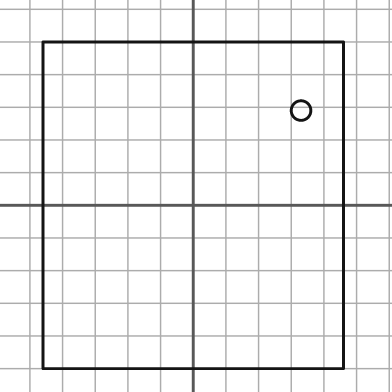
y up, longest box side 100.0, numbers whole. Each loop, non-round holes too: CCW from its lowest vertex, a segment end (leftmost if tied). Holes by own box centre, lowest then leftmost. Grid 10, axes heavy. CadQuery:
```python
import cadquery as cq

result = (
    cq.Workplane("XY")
    .moveTo(-46.0, -50.0)
    .lineTo(46.0, -50.0)
    .lineTo(46.0, 50.0)
    .lineTo(-46.0, 50.0)
    .close()
    .moveTo(33.0, 29.0)
    .circle(3.0)
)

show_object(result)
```